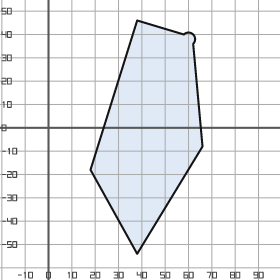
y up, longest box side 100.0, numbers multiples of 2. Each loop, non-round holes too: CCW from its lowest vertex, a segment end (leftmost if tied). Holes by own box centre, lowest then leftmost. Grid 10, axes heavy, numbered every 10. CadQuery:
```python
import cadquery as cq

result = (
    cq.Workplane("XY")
    .moveTo(38.0, -54.0)
    .lineTo(66.0, -8.0)
    .lineTo(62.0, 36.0)
    .threePointArc((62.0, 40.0), (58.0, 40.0))
    .lineTo(38.0, 46.0)
    .lineTo(18.0, -18.0)
    .close()
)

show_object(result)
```